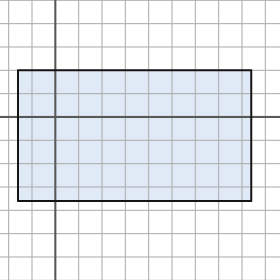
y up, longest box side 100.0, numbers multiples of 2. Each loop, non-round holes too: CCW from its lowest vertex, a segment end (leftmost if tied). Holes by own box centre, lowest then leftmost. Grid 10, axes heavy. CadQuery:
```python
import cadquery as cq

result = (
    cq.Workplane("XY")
    .moveTo(-16.0, -36.0)
    .lineTo(84.0, -36.0)
    .lineTo(84.0, 20.0)
    .lineTo(-16.0, 20.0)
    .close()
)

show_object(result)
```